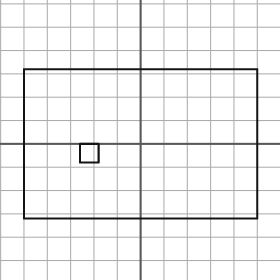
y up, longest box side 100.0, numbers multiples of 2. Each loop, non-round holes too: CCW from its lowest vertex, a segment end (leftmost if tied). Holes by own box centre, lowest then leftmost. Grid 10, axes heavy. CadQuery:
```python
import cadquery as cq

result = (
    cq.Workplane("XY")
    .moveTo(-50.0, -32.0)
    .lineTo(50.0, -32.0)
    .lineTo(50.0, 32.0)
    .lineTo(-50.0, 32.0)
    .close()
    .moveTo(-26.0, -8.0)
    .lineTo(-18.0, -8.0)
    .lineTo(-18.0, 0.0)
    .lineTo(-26.0, 0.0)
    .close()
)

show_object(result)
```